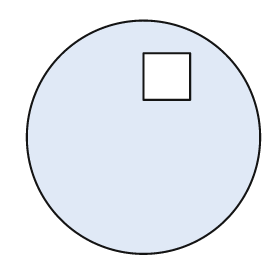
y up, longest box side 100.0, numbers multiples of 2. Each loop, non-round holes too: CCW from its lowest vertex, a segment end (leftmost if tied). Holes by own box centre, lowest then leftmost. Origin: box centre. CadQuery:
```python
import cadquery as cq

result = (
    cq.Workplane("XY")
    .moveTo(0.0, 0.0)
    .circle(50.0)
    .moveTo(0.0, 16.0)
    .lineTo(20.0, 16.0)
    .lineTo(20.0, 36.0)
    .lineTo(0.0, 36.0)
    .close()
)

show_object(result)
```